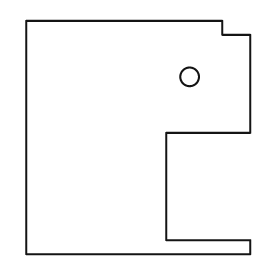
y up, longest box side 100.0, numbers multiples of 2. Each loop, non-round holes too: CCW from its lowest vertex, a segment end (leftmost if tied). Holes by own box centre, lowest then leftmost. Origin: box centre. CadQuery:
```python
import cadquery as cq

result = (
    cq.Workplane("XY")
    .moveTo(-48.0, -50.0)
    .lineTo(48.0, -50.0)
    .lineTo(48.0, -44.0)
    .lineTo(12.0, -44.0)
    .lineTo(12.0, 2.0)
    .lineTo(48.0, 2.0)
    .lineTo(48.0, 44.0)
    .lineTo(36.0, 44.0)
    .lineTo(36.0, 50.0)
    .lineTo(-48.0, 50.0)
    .close()
    .moveTo(22.0, 26.0)
    .circle(4.0)
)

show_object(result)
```